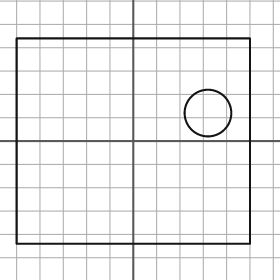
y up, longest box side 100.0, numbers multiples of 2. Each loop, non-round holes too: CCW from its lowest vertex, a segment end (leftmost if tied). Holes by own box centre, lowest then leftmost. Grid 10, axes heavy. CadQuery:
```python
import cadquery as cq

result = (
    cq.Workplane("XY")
    .moveTo(-50.0, -44.0)
    .lineTo(50.0, -44.0)
    .lineTo(50.0, 44.0)
    .lineTo(-50.0, 44.0)
    .close()
    .moveTo(32.0, 12.0)
    .circle(10.0)
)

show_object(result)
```